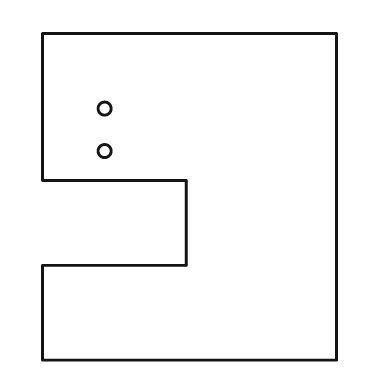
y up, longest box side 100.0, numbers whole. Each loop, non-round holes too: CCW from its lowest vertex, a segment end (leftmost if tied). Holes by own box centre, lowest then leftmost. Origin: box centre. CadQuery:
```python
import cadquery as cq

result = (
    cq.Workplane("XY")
    .moveTo(-45.0, -50.0)
    .lineTo(45.0, -50.0)
    .lineTo(45.0, 50.0)
    .lineTo(-45.0, 50.0)
    .lineTo(-45.0, 5.0)
    .lineTo(-1.0, 5.0)
    .lineTo(-1.0, -21.0)
    .lineTo(-45.0, -21.0)
    .close()
    .moveTo(-26.0, 14.0)
    .circle(2.0)
    .moveTo(-26.0, 27.0)
    .circle(2.0)
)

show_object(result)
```